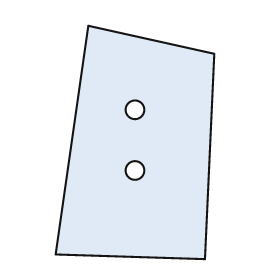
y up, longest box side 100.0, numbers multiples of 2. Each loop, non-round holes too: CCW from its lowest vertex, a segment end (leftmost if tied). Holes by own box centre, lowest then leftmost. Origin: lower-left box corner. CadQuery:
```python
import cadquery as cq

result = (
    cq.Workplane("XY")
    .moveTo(64.0, 0.0)
    .lineTo(68.0, 88.0)
    .lineTo(14.0, 100.0)
    .lineTo(0.0, 2.0)
    .close()
    .moveTo(34.0, 38.0)
    .circle(4.0)
    .moveTo(34.0, 64.0)
    .circle(4.0)
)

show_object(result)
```